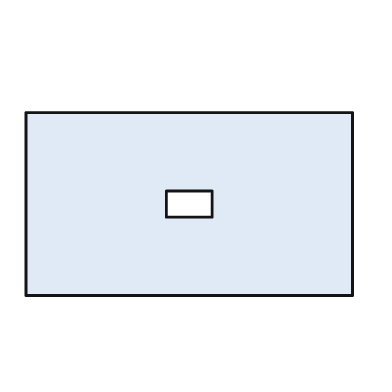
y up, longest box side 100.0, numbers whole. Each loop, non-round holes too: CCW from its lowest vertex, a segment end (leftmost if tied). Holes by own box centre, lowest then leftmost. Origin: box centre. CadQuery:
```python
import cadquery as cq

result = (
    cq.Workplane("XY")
    .moveTo(-50.0, -28.0)
    .lineTo(50.0, -28.0)
    .lineTo(50.0, 28.0)
    .lineTo(-50.0, 28.0)
    .close()
    .moveTo(-7.0, -4.0)
    .lineTo(7.0, -4.0)
    .lineTo(7.0, 4.0)
    .lineTo(-7.0, 4.0)
    .close()
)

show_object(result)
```